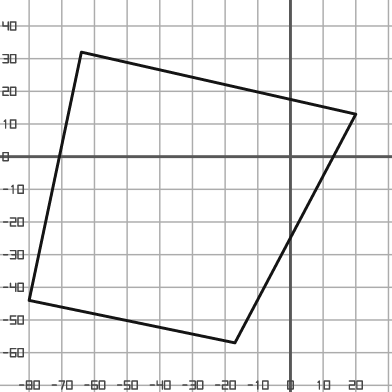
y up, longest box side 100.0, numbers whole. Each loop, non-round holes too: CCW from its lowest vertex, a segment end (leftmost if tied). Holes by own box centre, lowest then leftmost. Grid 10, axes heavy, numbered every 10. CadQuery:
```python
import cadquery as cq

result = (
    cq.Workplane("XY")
    .moveTo(-17.0, -57.0)
    .lineTo(20.0, 13.0)
    .lineTo(-64.0, 32.0)
    .lineTo(-80.0, -44.0)
    .close()
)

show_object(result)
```